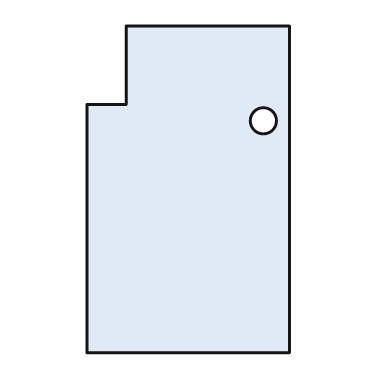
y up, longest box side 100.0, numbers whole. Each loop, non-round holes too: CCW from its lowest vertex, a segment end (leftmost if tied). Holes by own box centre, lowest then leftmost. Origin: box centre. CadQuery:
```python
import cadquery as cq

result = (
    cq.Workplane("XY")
    .moveTo(-31.0, -50.0)
    .lineTo(31.0, -50.0)
    .lineTo(31.0, 50.0)
    .lineTo(-19.0, 50.0)
    .lineTo(-19.0, 26.0)
    .lineTo(-31.0, 26.0)
    .close()
    .moveTo(23.0, 21.0)
    .circle(4.0)
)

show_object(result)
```